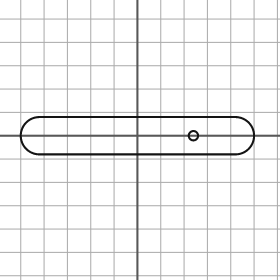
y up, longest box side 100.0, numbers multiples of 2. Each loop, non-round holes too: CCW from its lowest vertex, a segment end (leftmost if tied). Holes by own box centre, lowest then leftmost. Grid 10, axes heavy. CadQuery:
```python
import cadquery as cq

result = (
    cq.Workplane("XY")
    .moveTo(-42.0, -8.0)
    .lineTo(42.0, -8.0)
    .threePointArc((50.0, 0.0), (42.0, 8.0))
    .lineTo(-42.0, 8.0)
    .threePointArc((-50.0, 0.0), (-42.0, -8.0))
    .close()
    .moveTo(24.0, 0.0)
    .circle(2.0)
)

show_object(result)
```